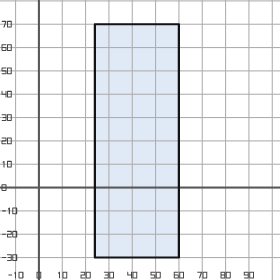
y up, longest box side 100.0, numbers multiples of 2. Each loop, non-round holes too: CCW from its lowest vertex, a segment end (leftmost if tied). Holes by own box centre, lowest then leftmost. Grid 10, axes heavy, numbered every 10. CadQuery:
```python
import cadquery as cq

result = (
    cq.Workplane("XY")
    .moveTo(24.0, -30.0)
    .lineTo(60.0, -30.0)
    .lineTo(60.0, 70.0)
    .lineTo(24.0, 70.0)
    .close()
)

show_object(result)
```